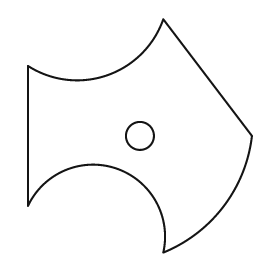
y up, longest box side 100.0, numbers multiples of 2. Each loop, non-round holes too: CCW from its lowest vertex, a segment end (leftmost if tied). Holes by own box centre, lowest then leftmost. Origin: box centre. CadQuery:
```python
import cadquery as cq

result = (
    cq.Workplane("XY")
    .moveTo(10.0, -50.0)
    .threePointArc((36.0, -30.0), (48.0, 0.0))
    .lineTo(10.0, 50.0)
    .threePointArc((-14.0, 26.0), (-48.0, 30.0))
    .lineTo(-48.0, -30.0)
    .threePointArc((-10.0, -14.0), (10.0, -50.0))
    .close()
    .moveTo(0.0, 0.0)
    .circle(6.0)
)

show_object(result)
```